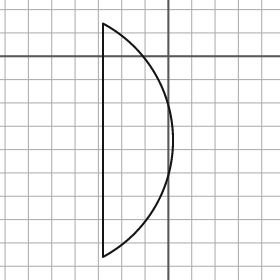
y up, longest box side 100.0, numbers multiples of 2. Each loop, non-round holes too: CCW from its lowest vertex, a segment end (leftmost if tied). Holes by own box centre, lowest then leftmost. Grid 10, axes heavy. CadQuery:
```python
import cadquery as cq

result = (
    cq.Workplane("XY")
    .moveTo(-28.0, -86.0)
    .threePointArc((2.0, -36.0), (-28.0, 14.0))
    .close()
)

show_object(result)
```